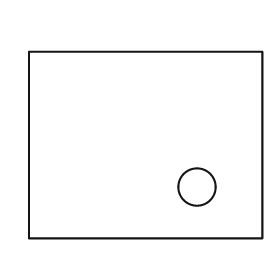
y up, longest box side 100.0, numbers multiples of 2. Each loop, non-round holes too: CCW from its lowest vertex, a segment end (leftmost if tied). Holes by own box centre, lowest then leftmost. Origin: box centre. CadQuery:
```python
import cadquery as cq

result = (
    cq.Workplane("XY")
    .moveTo(-50.0, -40.0)
    .lineTo(50.0, -40.0)
    .lineTo(50.0, 40.0)
    .lineTo(-50.0, 40.0)
    .close()
    .moveTo(22.0, -18.0)
    .circle(8.0)
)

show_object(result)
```